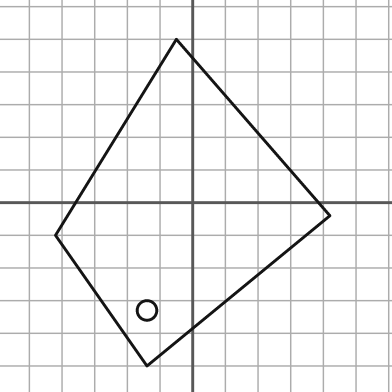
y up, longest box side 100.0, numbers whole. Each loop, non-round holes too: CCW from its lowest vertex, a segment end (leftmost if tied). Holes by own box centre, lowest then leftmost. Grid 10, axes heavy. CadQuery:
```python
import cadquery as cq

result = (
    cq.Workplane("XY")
    .moveTo(-14.0, -50.0)
    .lineTo(42.0, -4.0)
    .lineTo(-5.0, 50.0)
    .lineTo(-42.0, -10.0)
    .close()
    .moveTo(-14.0, -33.0)
    .circle(3.0)
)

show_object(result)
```